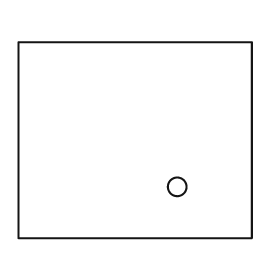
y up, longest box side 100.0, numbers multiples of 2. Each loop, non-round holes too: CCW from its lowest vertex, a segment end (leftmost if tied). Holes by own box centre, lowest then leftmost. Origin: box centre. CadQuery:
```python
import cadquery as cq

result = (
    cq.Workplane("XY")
    .moveTo(-50.0, -42.0)
    .lineTo(50.0, -42.0)
    .lineTo(50.0, 42.0)
    .lineTo(-50.0, 42.0)
    .close()
    .moveTo(18.0, -20.0)
    .circle(4.0)
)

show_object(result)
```